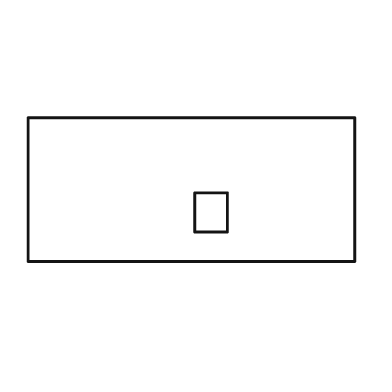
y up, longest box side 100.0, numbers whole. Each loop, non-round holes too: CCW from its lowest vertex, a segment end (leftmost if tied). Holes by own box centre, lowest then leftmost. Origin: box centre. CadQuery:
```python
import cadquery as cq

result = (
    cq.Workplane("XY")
    .moveTo(-50.0, -22.0)
    .lineTo(50.0, -22.0)
    .lineTo(50.0, 22.0)
    .lineTo(-50.0, 22.0)
    .close()
    .moveTo(1.0, -13.0)
    .lineTo(11.0, -13.0)
    .lineTo(11.0, -1.0)
    .lineTo(1.0, -1.0)
    .close()
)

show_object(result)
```